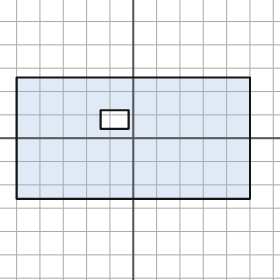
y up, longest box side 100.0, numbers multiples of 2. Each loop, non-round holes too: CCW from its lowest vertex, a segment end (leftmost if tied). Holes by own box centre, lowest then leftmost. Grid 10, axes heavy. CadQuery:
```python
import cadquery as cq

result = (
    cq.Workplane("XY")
    .moveTo(-50.0, -26.0)
    .lineTo(50.0, -26.0)
    .lineTo(50.0, 26.0)
    .lineTo(-50.0, 26.0)
    .close()
    .moveTo(-14.0, 4.0)
    .lineTo(-2.0, 4.0)
    .lineTo(-2.0, 12.0)
    .lineTo(-14.0, 12.0)
    .close()
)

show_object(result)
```